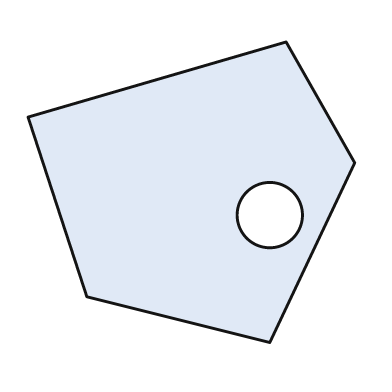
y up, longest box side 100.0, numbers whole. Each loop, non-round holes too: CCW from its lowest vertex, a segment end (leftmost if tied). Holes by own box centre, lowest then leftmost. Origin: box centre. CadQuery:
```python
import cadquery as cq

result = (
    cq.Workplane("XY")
    .moveTo(24.0, -46.0)
    .lineTo(50.0, 9.0)
    .lineTo(29.0, 46.0)
    .lineTo(-50.0, 23.0)
    .lineTo(-32.0, -32.0)
    .close()
    .moveTo(24.0, -7.0)
    .circle(10.0)
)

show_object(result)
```